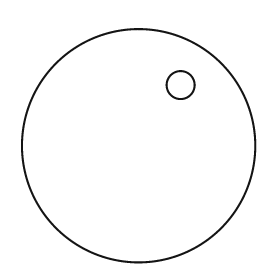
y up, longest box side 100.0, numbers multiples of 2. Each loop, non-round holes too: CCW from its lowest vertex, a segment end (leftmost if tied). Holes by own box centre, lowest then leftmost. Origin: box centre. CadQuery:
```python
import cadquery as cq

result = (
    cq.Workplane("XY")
    .moveTo(0.0, 0.0)
    .circle(50.0)
    .moveTo(18.0, 26.0)
    .circle(6.0)
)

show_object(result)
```